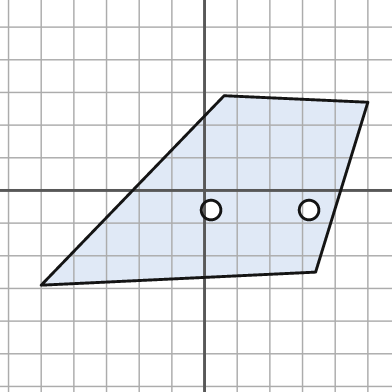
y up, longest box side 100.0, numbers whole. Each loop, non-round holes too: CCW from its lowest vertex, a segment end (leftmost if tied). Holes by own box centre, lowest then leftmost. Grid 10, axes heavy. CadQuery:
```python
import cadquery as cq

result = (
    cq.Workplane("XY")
    .moveTo(-50.0, -29.0)
    .lineTo(34.0, -25.0)
    .lineTo(50.0, 27.0)
    .lineTo(6.0, 29.0)
    .close()
    .moveTo(2.0, -6.0)
    .circle(3.0)
    .moveTo(32.0, -6.0)
    .circle(3.0)
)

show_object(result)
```